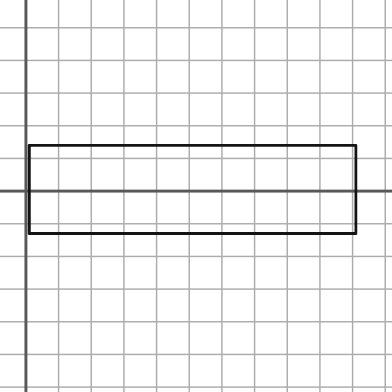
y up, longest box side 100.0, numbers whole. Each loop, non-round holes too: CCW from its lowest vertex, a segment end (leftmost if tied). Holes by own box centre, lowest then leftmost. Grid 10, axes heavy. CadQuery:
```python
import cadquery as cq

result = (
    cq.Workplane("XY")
    .moveTo(1.0, -13.0)
    .lineTo(101.0, -13.0)
    .lineTo(101.0, 14.0)
    .lineTo(1.0, 14.0)
    .close()
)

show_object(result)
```